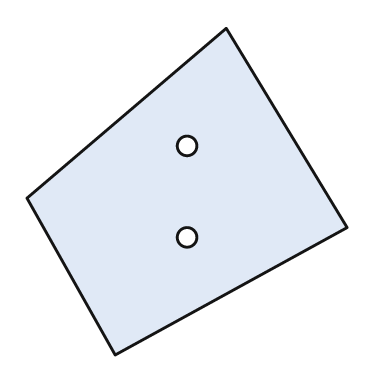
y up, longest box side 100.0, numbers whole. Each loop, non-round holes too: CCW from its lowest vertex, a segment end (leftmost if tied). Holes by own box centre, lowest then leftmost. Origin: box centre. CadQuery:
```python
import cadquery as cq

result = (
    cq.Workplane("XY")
    .moveTo(-22.0, -50.0)
    .lineTo(49.0, -11.0)
    .lineTo(12.0, 50.0)
    .lineTo(-49.0, -2.0)
    .close()
    .moveTo(0.0, -14.0)
    .circle(3.0)
    .moveTo(0.0, 14.0)
    .circle(3.0)
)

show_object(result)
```